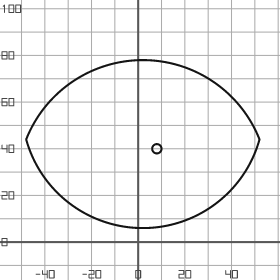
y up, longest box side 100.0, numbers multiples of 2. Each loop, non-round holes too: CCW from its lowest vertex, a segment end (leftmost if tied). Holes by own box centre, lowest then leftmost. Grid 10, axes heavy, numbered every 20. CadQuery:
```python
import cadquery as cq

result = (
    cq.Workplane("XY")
    .moveTo(-48.0, 44.0)
    .threePointArc((2.0, 6.0), (52.0, 44.0))
    .threePointArc((2.0, 78.0), (-48.0, 44.0))
    .close()
    .moveTo(8.0, 40.0)
    .circle(2.0)
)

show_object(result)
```